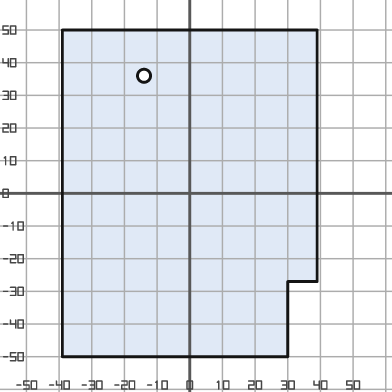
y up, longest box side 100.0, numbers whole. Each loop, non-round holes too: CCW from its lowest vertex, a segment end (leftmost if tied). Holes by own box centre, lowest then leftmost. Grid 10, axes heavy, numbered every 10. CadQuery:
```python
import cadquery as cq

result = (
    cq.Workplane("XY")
    .moveTo(-39.0, -50.0)
    .lineTo(30.0, -50.0)
    .lineTo(30.0, -27.0)
    .lineTo(39.0, -27.0)
    .lineTo(39.0, 50.0)
    .lineTo(-39.0, 50.0)
    .close()
    .moveTo(-14.0, 36.0)
    .circle(2.0)
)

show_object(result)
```